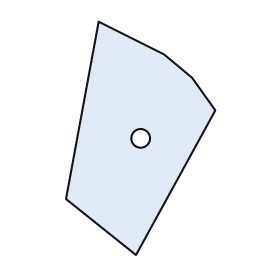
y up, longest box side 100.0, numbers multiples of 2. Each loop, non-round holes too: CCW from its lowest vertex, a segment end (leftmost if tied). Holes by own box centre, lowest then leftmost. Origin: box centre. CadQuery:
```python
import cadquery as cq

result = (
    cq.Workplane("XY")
    .moveTo(-2.0, -50.0)
    .lineTo(32.0, 12.0)
    .lineTo(22.0, 26.0)
    .lineTo(10.0, 36.0)
    .lineTo(-18.0, 50.0)
    .lineTo(-32.0, -26.0)
    .close()
    .moveTo(0.0, 0.0)
    .circle(4.0)
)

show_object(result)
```